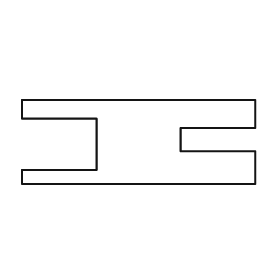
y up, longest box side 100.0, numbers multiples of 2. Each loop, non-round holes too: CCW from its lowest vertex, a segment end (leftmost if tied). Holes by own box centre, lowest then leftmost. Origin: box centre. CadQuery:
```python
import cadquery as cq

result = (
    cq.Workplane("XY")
    .moveTo(-50.0, -18.0)
    .lineTo(50.0, -18.0)
    .lineTo(50.0, -4.0)
    .lineTo(18.0, -4.0)
    .lineTo(18.0, 6.0)
    .lineTo(50.0, 6.0)
    .lineTo(50.0, 18.0)
    .lineTo(-50.0, 18.0)
    .lineTo(-50.0, 10.0)
    .lineTo(-18.0, 10.0)
    .lineTo(-18.0, -12.0)
    .lineTo(-50.0, -12.0)
    .close()
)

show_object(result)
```